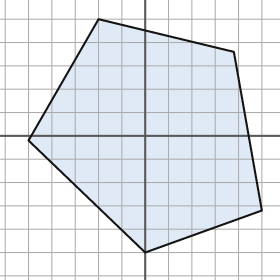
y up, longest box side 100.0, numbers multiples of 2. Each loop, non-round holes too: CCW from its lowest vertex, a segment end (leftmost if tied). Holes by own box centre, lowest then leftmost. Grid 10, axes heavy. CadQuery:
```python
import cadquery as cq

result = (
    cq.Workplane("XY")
    .moveTo(0.0, -50.0)
    .lineTo(50.0, -32.0)
    .lineTo(38.0, 36.0)
    .lineTo(-20.0, 50.0)
    .lineTo(-50.0, -2.0)
    .close()
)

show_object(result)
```